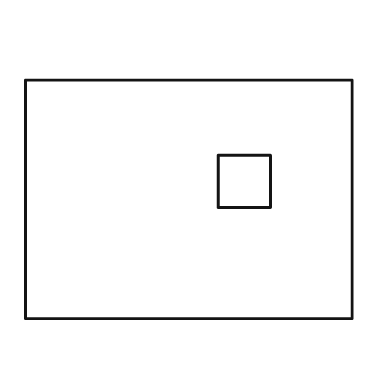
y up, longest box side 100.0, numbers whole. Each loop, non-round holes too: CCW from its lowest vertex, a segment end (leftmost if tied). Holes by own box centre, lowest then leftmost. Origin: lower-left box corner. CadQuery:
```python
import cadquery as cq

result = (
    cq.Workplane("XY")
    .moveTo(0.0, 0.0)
    .lineTo(100.0, 0.0)
    .lineTo(100.0, 73.0)
    .lineTo(0.0, 73.0)
    .close()
    .moveTo(59.0, 34.0)
    .lineTo(75.0, 34.0)
    .lineTo(75.0, 50.0)
    .lineTo(59.0, 50.0)
    .close()
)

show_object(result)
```